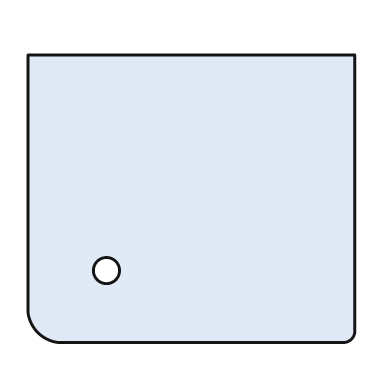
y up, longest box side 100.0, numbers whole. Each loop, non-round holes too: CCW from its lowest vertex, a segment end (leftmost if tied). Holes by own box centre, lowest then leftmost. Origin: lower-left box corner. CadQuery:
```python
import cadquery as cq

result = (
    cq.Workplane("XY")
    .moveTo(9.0, 0.0)
    .lineTo(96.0, 0.0)
    .threePointArc((99.0, 1.0), (100.0, 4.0))
    .lineTo(100.0, 88.0)
    .lineTo(0.0, 88.0)
    .lineTo(0.0, 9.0)
    .threePointArc((3.0, 3.0), (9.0, 0.0))
    .close()
    .moveTo(24.0, 22.0)
    .circle(4.0)
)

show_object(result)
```